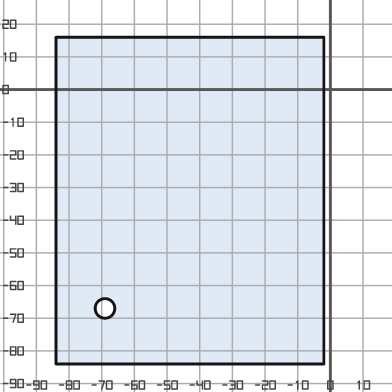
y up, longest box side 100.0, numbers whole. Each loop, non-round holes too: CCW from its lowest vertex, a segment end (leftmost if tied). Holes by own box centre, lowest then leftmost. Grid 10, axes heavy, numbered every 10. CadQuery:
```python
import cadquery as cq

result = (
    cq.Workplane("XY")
    .moveTo(-84.0, -84.0)
    .lineTo(-2.0, -84.0)
    .lineTo(-2.0, 16.0)
    .lineTo(-84.0, 16.0)
    .close()
    .moveTo(-69.0, -67.0)
    .circle(3.0)
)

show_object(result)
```